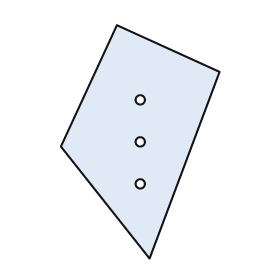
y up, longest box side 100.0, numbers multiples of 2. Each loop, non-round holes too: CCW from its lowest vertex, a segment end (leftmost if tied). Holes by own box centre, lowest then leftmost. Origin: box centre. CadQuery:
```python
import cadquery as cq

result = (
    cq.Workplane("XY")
    .moveTo(4.0, -50.0)
    .lineTo(34.0, 30.0)
    .lineTo(-10.0, 50.0)
    .lineTo(-34.0, -2.0)
    .close()
    .moveTo(0.0, -18.0)
    .circle(2.0)
    .moveTo(0.0, 0.0)
    .circle(2.0)
    .moveTo(0.0, 18.0)
    .circle(2.0)
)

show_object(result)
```